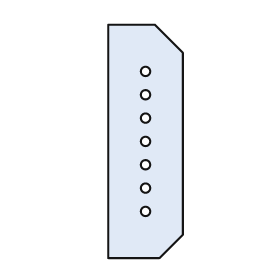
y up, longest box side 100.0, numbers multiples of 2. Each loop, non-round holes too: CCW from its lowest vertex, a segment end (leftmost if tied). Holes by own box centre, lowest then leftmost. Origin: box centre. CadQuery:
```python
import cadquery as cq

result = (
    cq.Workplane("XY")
    .moveTo(-16.0, -50.0)
    .lineTo(6.0, -50.0)
    .lineTo(16.0, -40.0)
    .lineTo(16.0, 38.0)
    .lineTo(4.0, 50.0)
    .lineTo(-16.0, 50.0)
    .close()
    .moveTo(0.0, -30.0)
    .circle(2.0)
    .moveTo(0.0, -20.0)
    .circle(2.0)
    .moveTo(0.0, -10.0)
    .circle(2.0)
    .moveTo(0.0, 0.0)
    .circle(2.0)
    .moveTo(0.0, 10.0)
    .circle(2.0)
    .moveTo(0.0, 20.0)
    .circle(2.0)
    .moveTo(0.0, 30.0)
    .circle(2.0)
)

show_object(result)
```